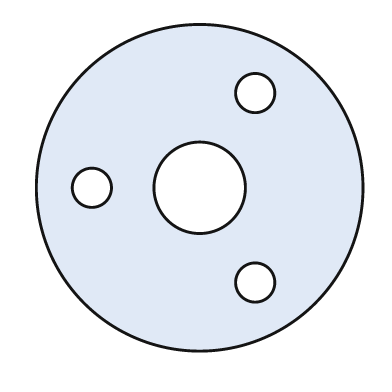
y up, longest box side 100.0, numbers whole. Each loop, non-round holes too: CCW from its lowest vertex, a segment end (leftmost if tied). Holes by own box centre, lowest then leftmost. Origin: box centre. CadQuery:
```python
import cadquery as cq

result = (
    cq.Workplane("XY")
    .moveTo(0.0, 0.0)
    .circle(50.0)
    .moveTo(17.0, -29.0)
    .circle(6.0)
    .moveTo(-33.0, 0.0)
    .circle(6.0)
    .moveTo(0.0, 0.0)
    .circle(14.0)
    .moveTo(17.0, 29.0)
    .circle(6.0)
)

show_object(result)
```